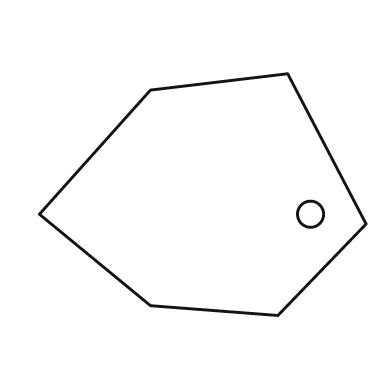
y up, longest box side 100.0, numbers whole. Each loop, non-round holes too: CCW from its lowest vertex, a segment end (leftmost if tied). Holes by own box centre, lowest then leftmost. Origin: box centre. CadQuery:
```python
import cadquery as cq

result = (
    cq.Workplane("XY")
    .moveTo(23.0, -37.0)
    .lineTo(50.0, -9.0)
    .lineTo(26.0, 37.0)
    .lineTo(-16.0, 32.0)
    .lineTo(-50.0, -6.0)
    .lineTo(-16.0, -34.0)
    .close()
    .moveTo(33.0, -6.0)
    .circle(4.0)
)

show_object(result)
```